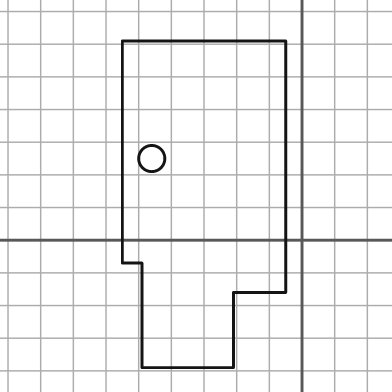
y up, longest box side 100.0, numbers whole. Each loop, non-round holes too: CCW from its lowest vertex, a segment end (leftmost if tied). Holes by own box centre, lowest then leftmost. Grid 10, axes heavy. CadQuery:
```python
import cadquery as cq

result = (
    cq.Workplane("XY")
    .moveTo(-49.0, -39.0)
    .lineTo(-21.0, -39.0)
    .lineTo(-21.0, -16.0)
    .lineTo(-5.0, -16.0)
    .lineTo(-5.0, 61.0)
    .lineTo(-55.0, 61.0)
    .lineTo(-55.0, -7.0)
    .lineTo(-49.0, -7.0)
    .close()
    .moveTo(-46.0, 25.0)
    .circle(4.0)
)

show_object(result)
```